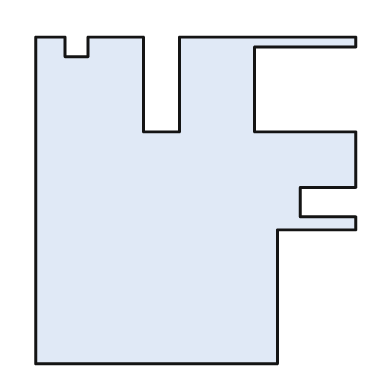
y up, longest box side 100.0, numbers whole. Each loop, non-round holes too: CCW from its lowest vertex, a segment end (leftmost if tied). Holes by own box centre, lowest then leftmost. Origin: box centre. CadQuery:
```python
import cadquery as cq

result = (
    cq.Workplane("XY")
    .moveTo(-49.0, -50.0)
    .lineTo(25.0, -50.0)
    .lineTo(25.0, -9.0)
    .lineTo(49.0, -9.0)
    .lineTo(49.0, -5.0)
    .lineTo(32.0, -5.0)
    .lineTo(32.0, 4.0)
    .lineTo(49.0, 4.0)
    .lineTo(49.0, 21.0)
    .lineTo(18.0, 21.0)
    .lineTo(18.0, 47.0)
    .lineTo(49.0, 47.0)
    .lineTo(49.0, 50.0)
    .lineTo(-5.0, 50.0)
    .lineTo(-5.0, 21.0)
    .lineTo(-16.0, 21.0)
    .lineTo(-16.0, 50.0)
    .lineTo(-33.0, 50.0)
    .lineTo(-33.0, 44.0)
    .lineTo(-40.0, 44.0)
    .lineTo(-40.0, 50.0)
    .lineTo(-49.0, 50.0)
    .close()
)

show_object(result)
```